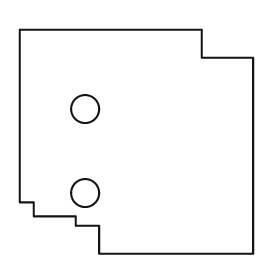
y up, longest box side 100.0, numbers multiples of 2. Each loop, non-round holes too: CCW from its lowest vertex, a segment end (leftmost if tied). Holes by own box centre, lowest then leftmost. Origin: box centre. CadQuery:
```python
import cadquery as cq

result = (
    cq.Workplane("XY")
    .moveTo(-16.0, -48.0)
    .lineTo(50.0, -48.0)
    .lineTo(50.0, 36.0)
    .lineTo(28.0, 36.0)
    .lineTo(28.0, 48.0)
    .lineTo(-50.0, 48.0)
    .lineTo(-50.0, -26.0)
    .lineTo(-44.0, -26.0)
    .lineTo(-44.0, -32.0)
    .lineTo(-26.0, -32.0)
    .lineTo(-26.0, -36.0)
    .lineTo(-16.0, -36.0)
    .close()
    .moveTo(-22.0, -22.0)
    .circle(6.0)
    .moveTo(-22.0, 14.0)
    .circle(6.0)
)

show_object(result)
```